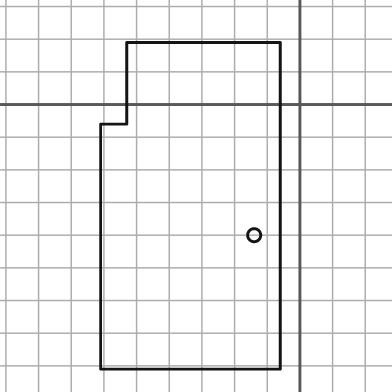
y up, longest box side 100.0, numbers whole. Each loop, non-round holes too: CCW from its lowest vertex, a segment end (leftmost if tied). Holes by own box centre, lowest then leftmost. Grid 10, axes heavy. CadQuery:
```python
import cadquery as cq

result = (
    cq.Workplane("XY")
    .moveTo(-61.0, -81.0)
    .lineTo(-6.0, -81.0)
    .lineTo(-6.0, 19.0)
    .lineTo(-53.0, 19.0)
    .lineTo(-53.0, -6.0)
    .lineTo(-61.0, -6.0)
    .close()
    .moveTo(-14.0, -40.0)
    .circle(2.0)
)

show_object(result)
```